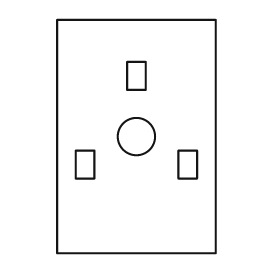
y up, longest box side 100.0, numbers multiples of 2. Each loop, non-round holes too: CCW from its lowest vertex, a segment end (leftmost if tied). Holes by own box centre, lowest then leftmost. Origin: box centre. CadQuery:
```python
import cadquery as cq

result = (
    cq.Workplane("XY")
    .moveTo(-34.0, -50.0)
    .lineTo(34.0, -50.0)
    .lineTo(34.0, 50.0)
    .lineTo(-34.0, 50.0)
    .close()
    .moveTo(-26.0, -18.0)
    .lineTo(-18.0, -18.0)
    .lineTo(-18.0, -6.0)
    .lineTo(-26.0, -6.0)
    .close()
    .moveTo(18.0, -18.0)
    .lineTo(26.0, -18.0)
    .lineTo(26.0, -6.0)
    .lineTo(18.0, -6.0)
    .close()
    .moveTo(0.0, 0.0)
    .circle(8.0)
    .moveTo(-4.0, 20.0)
    .lineTo(4.0, 20.0)
    .lineTo(4.0, 32.0)
    .lineTo(-4.0, 32.0)
    .close()
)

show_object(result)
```